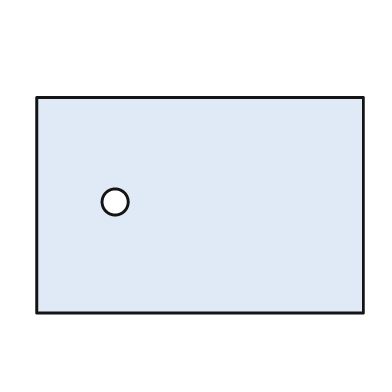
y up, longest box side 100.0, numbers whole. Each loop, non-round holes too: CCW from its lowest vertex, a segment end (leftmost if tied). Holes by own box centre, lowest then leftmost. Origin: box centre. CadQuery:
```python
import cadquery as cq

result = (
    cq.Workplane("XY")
    .moveTo(-50.0, -33.0)
    .lineTo(50.0, -33.0)
    .lineTo(50.0, 33.0)
    .lineTo(-50.0, 33.0)
    .close()
    .moveTo(-26.0, 1.0)
    .circle(4.0)
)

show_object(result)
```